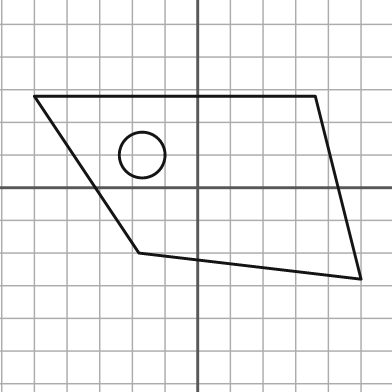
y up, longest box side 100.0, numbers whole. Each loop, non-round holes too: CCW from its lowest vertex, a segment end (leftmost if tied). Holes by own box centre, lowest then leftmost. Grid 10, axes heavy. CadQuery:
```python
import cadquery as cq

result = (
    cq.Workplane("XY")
    .moveTo(50.0, -28.0)
    .lineTo(36.0, 28.0)
    .lineTo(-50.0, 28.0)
    .lineTo(-18.0, -20.0)
    .close()
    .moveTo(-17.0, 10.0)
    .circle(7.0)
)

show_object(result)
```